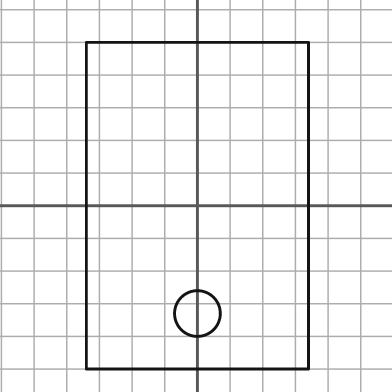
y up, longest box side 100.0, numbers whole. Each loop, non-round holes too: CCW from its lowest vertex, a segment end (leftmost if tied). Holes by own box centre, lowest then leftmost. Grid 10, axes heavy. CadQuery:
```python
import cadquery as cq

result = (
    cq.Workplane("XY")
    .moveTo(-34.0, -50.0)
    .lineTo(34.0, -50.0)
    .lineTo(34.0, 50.0)
    .lineTo(-34.0, 50.0)
    .close()
    .moveTo(0.0, -33.0)
    .circle(7.0)
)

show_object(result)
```